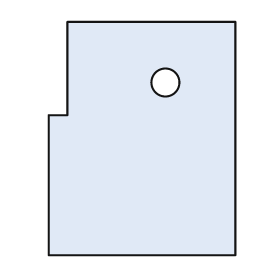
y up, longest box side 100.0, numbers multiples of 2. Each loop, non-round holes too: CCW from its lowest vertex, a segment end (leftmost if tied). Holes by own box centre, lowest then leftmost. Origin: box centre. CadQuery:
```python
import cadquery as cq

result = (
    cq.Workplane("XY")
    .moveTo(-40.0, -50.0)
    .lineTo(40.0, -50.0)
    .lineTo(40.0, 50.0)
    .lineTo(-32.0, 50.0)
    .lineTo(-32.0, 10.0)
    .lineTo(-40.0, 10.0)
    .close()
    .moveTo(10.0, 24.0)
    .circle(6.0)
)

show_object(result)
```